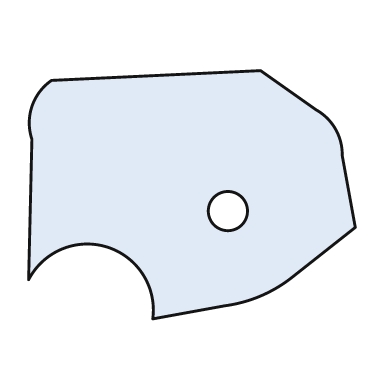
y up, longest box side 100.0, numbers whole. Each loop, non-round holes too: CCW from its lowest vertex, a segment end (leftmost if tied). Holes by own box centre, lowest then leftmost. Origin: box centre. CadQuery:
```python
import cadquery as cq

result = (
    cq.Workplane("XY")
    .moveTo(-12.0, -38.0)
    .lineTo(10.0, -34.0)
    .threePointArc((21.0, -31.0), (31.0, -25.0))
    .lineTo(50.0, -10.0)
    .lineTo(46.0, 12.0)
    .threePointArc((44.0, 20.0), (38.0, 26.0))
    .lineTo(21.0, 38.0)
    .lineTo(-43.0, 35.0)
    .threePointArc((-49.0, 27.0), (-49.0, 17.0))
    .lineTo(-50.0, -26.0)
    .threePointArc((-26.0, -16.0), (-12.0, -38.0))
    .close()
    .moveTo(11.0, -5.0)
    .circle(6.0)
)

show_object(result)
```